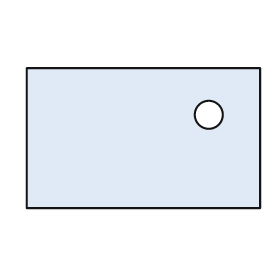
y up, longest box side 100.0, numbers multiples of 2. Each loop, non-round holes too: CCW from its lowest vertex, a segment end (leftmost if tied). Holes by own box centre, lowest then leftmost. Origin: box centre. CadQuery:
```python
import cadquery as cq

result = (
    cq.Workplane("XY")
    .moveTo(-50.0, -30.0)
    .lineTo(50.0, -30.0)
    .lineTo(50.0, 30.0)
    .lineTo(-50.0, 30.0)
    .close()
    .moveTo(28.0, 10.0)
    .circle(6.0)
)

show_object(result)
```